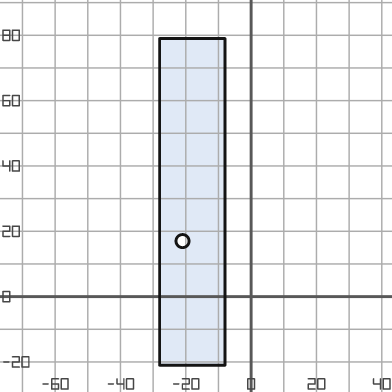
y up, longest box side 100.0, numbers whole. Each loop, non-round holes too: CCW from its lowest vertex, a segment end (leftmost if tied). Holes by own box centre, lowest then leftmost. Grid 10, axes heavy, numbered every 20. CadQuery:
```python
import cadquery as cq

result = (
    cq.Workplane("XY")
    .moveTo(-28.0, -21.0)
    .lineTo(-8.0, -21.0)
    .lineTo(-8.0, 79.0)
    .lineTo(-28.0, 79.0)
    .close()
    .moveTo(-21.0, 17.0)
    .circle(2.0)
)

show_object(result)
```